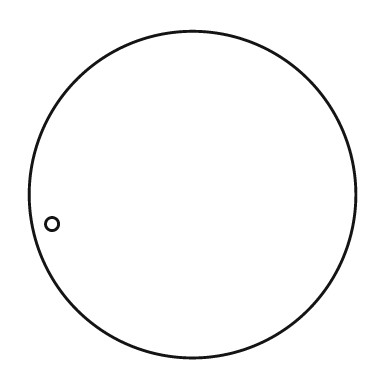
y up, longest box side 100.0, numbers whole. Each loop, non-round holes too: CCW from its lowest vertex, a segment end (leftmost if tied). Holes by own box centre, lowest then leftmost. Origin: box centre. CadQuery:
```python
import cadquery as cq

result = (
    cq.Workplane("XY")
    .moveTo(0.0, 0.0)
    .circle(50.0)
    .moveTo(-43.0, -9.0)
    .circle(2.0)
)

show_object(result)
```